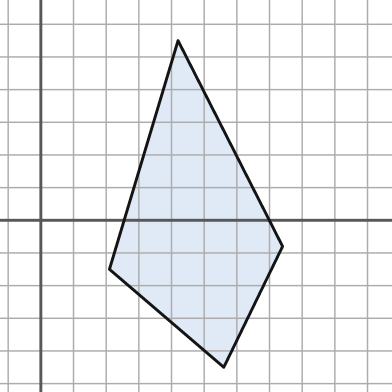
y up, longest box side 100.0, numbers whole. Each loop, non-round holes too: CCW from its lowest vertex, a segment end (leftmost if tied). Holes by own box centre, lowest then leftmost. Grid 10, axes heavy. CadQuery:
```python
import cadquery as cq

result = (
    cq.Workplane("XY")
    .moveTo(56.0, -45.0)
    .lineTo(74.0, -8.0)
    .lineTo(42.0, 55.0)
    .lineTo(21.0, -15.0)
    .close()
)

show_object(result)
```